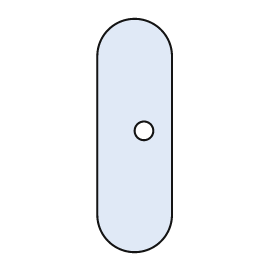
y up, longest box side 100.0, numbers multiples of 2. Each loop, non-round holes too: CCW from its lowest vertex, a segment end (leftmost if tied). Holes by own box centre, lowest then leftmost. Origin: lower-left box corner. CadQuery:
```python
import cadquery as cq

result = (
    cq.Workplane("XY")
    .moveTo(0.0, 16.0)
    .threePointArc((16.0, 0.0), (32.0, 16.0))
    .lineTo(32.0, 84.0)
    .threePointArc((16.0, 100.0), (0.0, 84.0))
    .close()
    .moveTo(20.0, 52.0)
    .circle(4.0)
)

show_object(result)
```